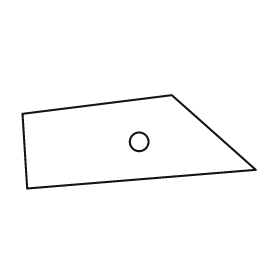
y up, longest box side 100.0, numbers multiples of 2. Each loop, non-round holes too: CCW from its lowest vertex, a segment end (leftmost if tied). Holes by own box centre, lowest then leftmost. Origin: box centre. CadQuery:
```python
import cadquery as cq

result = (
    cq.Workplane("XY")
    .moveTo(-48.0, -20.0)
    .lineTo(50.0, -12.0)
    .lineTo(14.0, 20.0)
    .lineTo(-50.0, 12.0)
    .close()
    .moveTo(0.0, 0.0)
    .circle(4.0)
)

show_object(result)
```